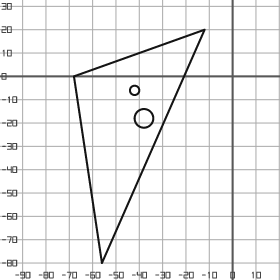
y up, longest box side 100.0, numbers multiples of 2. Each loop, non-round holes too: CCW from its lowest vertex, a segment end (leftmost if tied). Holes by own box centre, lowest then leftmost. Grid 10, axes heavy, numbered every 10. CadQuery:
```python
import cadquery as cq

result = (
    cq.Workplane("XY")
    .moveTo(-56.0, -80.0)
    .lineTo(-12.0, 20.0)
    .lineTo(-68.0, 0.0)
    .close()
    .moveTo(-38.0, -18.0)
    .circle(4.0)
    .moveTo(-42.0, -6.0)
    .circle(2.0)
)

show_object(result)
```